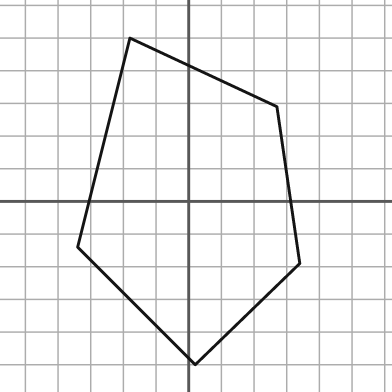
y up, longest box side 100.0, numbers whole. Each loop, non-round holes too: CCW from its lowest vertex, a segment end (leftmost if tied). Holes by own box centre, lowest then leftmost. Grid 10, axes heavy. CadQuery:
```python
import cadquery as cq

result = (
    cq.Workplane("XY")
    .moveTo(2.0, -50.0)
    .lineTo(34.0, -19.0)
    .lineTo(27.0, 29.0)
    .lineTo(-18.0, 50.0)
    .lineTo(-34.0, -14.0)
    .close()
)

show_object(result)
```